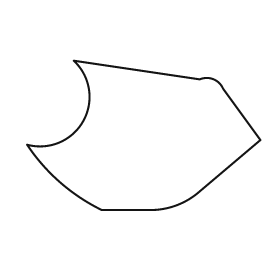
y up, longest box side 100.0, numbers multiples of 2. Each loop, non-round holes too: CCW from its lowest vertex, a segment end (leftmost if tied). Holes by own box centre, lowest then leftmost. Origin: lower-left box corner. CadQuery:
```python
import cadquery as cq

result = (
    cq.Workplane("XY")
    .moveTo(32.0, 0.0)
    .lineTo(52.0, 0.0)
    .threePointArc((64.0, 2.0), (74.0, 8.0))
    .lineTo(100.0, 30.0)
    .lineTo(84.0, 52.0)
    .threePointArc((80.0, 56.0), (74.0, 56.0))
    .lineTo(20.0, 64.0)
    .threePointArc((24.0, 38.0), (0.0, 28.0))
    .threePointArc((14.0, 12.0), (32.0, 0.0))
    .close()
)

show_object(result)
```